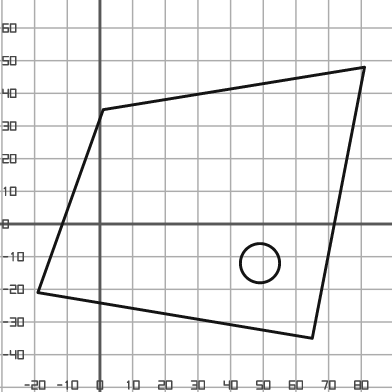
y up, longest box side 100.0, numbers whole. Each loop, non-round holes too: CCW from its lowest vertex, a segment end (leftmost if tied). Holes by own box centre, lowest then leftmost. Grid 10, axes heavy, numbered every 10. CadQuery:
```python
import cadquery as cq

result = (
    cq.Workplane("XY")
    .moveTo(65.0, -35.0)
    .lineTo(81.0, 48.0)
    .lineTo(1.0, 35.0)
    .lineTo(-19.0, -21.0)
    .close()
    .moveTo(49.0, -12.0)
    .circle(6.0)
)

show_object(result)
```